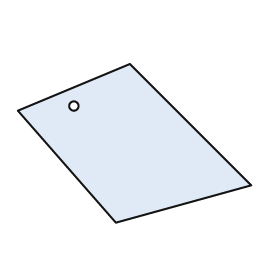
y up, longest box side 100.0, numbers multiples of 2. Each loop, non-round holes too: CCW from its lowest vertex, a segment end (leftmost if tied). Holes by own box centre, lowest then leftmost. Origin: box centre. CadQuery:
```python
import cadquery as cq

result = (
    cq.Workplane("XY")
    .moveTo(-8.0, -34.0)
    .lineTo(50.0, -18.0)
    .lineTo(-2.0, 34.0)
    .lineTo(-50.0, 14.0)
    .close()
    .moveTo(-26.0, 16.0)
    .circle(2.0)
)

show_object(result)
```